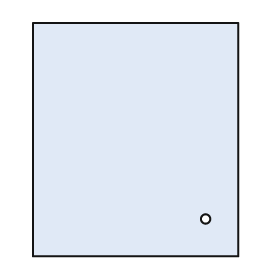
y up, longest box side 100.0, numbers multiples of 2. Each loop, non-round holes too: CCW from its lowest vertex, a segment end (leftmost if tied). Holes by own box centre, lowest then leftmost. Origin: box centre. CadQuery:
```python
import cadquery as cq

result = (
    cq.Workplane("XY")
    .moveTo(-44.0, -50.0)
    .lineTo(44.0, -50.0)
    .lineTo(44.0, 50.0)
    .lineTo(-44.0, 50.0)
    .close()
    .moveTo(30.0, -34.0)
    .circle(2.0)
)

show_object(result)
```